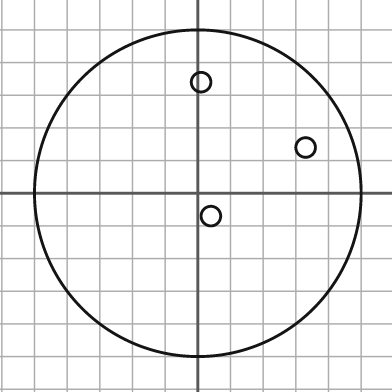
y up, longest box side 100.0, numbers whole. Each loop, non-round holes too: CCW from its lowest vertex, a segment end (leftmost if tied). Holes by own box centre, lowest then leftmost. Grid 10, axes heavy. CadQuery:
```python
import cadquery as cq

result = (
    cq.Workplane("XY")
    .moveTo(0.0, 0.0)
    .circle(50.0)
    .moveTo(4.0, -7.0)
    .circle(3.0)
    .moveTo(33.0, 14.0)
    .circle(3.0)
    .moveTo(1.0, 34.0)
    .circle(3.0)
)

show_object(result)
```